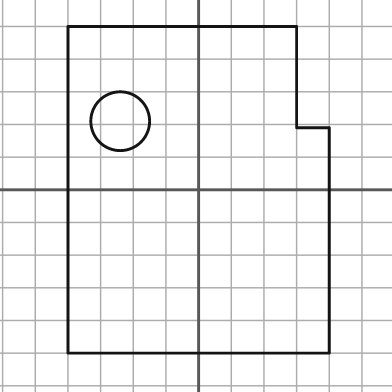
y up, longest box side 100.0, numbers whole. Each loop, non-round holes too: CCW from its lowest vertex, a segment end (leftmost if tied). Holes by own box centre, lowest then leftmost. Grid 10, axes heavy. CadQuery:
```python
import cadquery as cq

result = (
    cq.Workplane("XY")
    .moveTo(-40.0, -50.0)
    .lineTo(40.0, -50.0)
    .lineTo(40.0, 19.0)
    .lineTo(30.0, 19.0)
    .lineTo(30.0, 50.0)
    .lineTo(-40.0, 50.0)
    .close()
    .moveTo(-24.0, 21.0)
    .circle(9.0)
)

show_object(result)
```